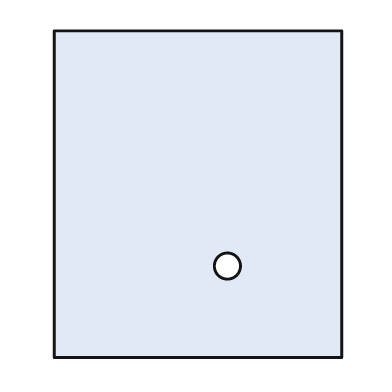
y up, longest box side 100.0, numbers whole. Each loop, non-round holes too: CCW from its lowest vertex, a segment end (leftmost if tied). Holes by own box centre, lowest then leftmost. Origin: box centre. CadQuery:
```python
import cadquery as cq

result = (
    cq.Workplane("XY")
    .moveTo(-44.0, -50.0)
    .lineTo(44.0, -50.0)
    .lineTo(44.0, 50.0)
    .lineTo(-44.0, 50.0)
    .close()
    .moveTo(9.0, -22.0)
    .circle(4.0)
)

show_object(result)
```